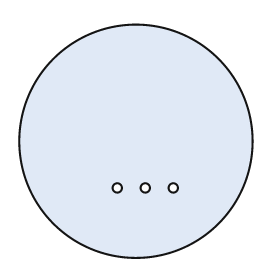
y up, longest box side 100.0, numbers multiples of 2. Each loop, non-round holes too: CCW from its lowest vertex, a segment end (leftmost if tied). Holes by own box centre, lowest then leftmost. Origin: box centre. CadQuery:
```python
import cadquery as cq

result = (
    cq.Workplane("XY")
    .moveTo(0.0, 0.0)
    .circle(50.0)
    .moveTo(-8.0, -20.0)
    .circle(2.0)
    .moveTo(4.0, -20.0)
    .circle(2.0)
    .moveTo(16.0, -20.0)
    .circle(2.0)
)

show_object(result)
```